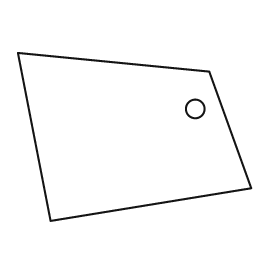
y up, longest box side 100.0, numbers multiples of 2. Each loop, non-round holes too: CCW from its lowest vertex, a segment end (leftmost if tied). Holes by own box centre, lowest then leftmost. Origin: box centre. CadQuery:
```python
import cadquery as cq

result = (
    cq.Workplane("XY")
    .moveTo(-36.0, -36.0)
    .lineTo(50.0, -22.0)
    .lineTo(32.0, 28.0)
    .lineTo(-50.0, 36.0)
    .close()
    .moveTo(26.0, 12.0)
    .circle(4.0)
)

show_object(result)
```